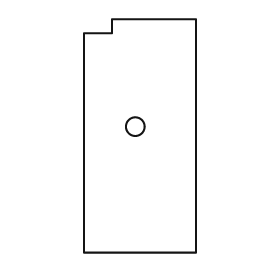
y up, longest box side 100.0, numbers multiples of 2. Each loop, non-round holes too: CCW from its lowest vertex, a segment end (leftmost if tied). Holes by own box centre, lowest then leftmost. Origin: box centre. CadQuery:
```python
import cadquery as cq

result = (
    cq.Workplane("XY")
    .moveTo(-24.0, -50.0)
    .lineTo(24.0, -50.0)
    .lineTo(24.0, 50.0)
    .lineTo(-12.0, 50.0)
    .lineTo(-12.0, 44.0)
    .lineTo(-24.0, 44.0)
    .close()
    .moveTo(-2.0, 4.0)
    .circle(4.0)
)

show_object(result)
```